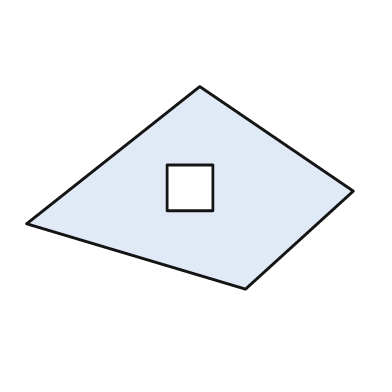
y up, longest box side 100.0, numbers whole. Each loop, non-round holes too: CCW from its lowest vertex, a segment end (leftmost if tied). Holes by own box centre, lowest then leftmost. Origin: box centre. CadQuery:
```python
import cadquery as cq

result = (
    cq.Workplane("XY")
    .moveTo(17.0, -31.0)
    .lineTo(50.0, -1.0)
    .lineTo(3.0, 31.0)
    .lineTo(-50.0, -11.0)
    .close()
    .moveTo(-7.0, -7.0)
    .lineTo(7.0, -7.0)
    .lineTo(7.0, 7.0)
    .lineTo(-7.0, 7.0)
    .close()
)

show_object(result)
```